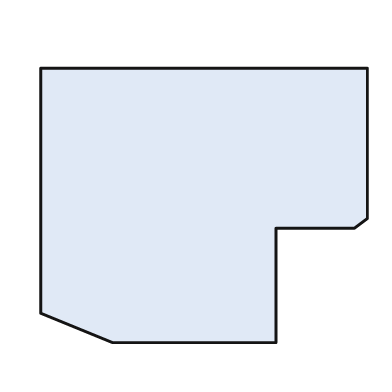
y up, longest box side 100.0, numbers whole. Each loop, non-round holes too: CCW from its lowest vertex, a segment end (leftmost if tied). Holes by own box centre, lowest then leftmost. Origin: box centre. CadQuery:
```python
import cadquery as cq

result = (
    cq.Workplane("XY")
    .moveTo(-28.0, -42.0)
    .lineTo(22.0, -42.0)
    .lineTo(22.0, -7.0)
    .lineTo(46.0, -7.0)
    .lineTo(50.0, -4.0)
    .lineTo(50.0, 42.0)
    .lineTo(-50.0, 42.0)
    .lineTo(-50.0, -33.0)
    .close()
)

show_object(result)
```